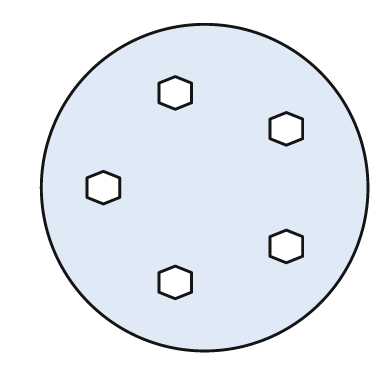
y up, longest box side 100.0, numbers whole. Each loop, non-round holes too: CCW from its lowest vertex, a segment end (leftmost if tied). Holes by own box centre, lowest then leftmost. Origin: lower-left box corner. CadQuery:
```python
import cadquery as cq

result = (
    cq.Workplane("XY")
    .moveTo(50.0, 50.0)
    .circle(50.0)
    .moveTo(41.0, 16.0)
    .lineTo(46.0, 18.0)
    .lineTo(46.0, 24.0)
    .lineTo(41.0, 26.0)
    .lineTo(36.0, 24.0)
    .lineTo(36.0, 18.0)
    .close()
    .moveTo(75.0, 27.0)
    .lineTo(80.0, 29.0)
    .lineTo(80.0, 35.0)
    .lineTo(75.0, 37.0)
    .lineTo(70.0, 35.0)
    .lineTo(70.0, 29.0)
    .close()
    .moveTo(19.0, 45.0)
    .lineTo(24.0, 47.0)
    .lineTo(24.0, 53.0)
    .lineTo(19.0, 55.0)
    .lineTo(14.0, 53.0)
    .lineTo(14.0, 47.0)
    .close()
    .moveTo(75.0, 63.0)
    .lineTo(80.0, 65.0)
    .lineTo(80.0, 71.0)
    .lineTo(75.0, 73.0)
    .lineTo(70.0, 71.0)
    .lineTo(70.0, 65.0)
    .close()
    .moveTo(41.0, 74.0)
    .lineTo(46.0, 76.0)
    .lineTo(46.0, 82.0)
    .lineTo(41.0, 84.0)
    .lineTo(36.0, 82.0)
    .lineTo(36.0, 76.0)
    .close()
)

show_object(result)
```